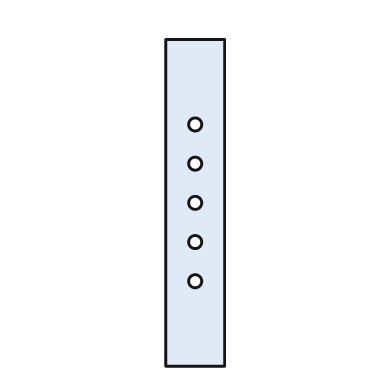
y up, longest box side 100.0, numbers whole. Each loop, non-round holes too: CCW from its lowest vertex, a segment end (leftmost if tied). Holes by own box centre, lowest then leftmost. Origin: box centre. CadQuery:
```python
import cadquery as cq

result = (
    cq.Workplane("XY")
    .moveTo(-9.0, -50.0)
    .lineTo(9.0, -50.0)
    .lineTo(9.0, 50.0)
    .lineTo(-9.0, 50.0)
    .close()
    .moveTo(0.0, -24.0)
    .circle(2.0)
    .moveTo(0.0, -12.0)
    .circle(2.0)
    .moveTo(0.0, 0.0)
    .circle(2.0)
    .moveTo(0.0, 12.0)
    .circle(2.0)
    .moveTo(0.0, 24.0)
    .circle(2.0)
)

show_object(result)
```